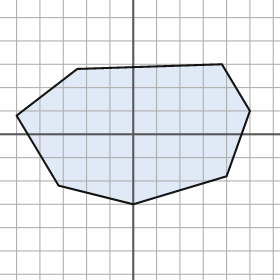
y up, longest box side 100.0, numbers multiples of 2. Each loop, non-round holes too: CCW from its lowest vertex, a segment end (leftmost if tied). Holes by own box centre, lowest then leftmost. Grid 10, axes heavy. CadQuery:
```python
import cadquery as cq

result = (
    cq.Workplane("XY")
    .moveTo(0.0, -30.0)
    .lineTo(40.0, -18.0)
    .lineTo(50.0, 10.0)
    .lineTo(38.0, 30.0)
    .lineTo(-24.0, 28.0)
    .lineTo(-50.0, 8.0)
    .lineTo(-32.0, -22.0)
    .close()
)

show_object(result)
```